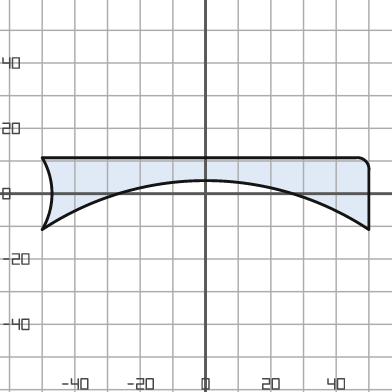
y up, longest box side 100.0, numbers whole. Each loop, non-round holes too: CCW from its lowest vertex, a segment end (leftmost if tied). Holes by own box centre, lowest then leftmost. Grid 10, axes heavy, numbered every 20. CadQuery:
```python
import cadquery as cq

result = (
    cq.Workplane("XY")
    .moveTo(-50.0, -11.0)
    .threePointArc((0.0, 4.0), (50.0, -11.0))
    .lineTo(50.0, 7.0)
    .threePointArc((49.0, 10.0), (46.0, 11.0))
    .lineTo(-50.0, 11.0)
    .threePointArc((-47.0, 0.0), (-50.0, -11.0))
    .close()
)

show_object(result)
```